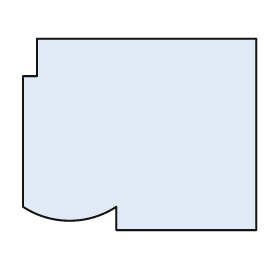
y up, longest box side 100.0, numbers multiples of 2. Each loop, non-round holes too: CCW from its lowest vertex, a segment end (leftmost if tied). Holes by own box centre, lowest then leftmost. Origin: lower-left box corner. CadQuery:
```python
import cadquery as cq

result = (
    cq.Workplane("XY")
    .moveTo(40.0, 0.0)
    .lineTo(100.0, 0.0)
    .lineTo(100.0, 82.0)
    .lineTo(6.0, 82.0)
    .lineTo(6.0, 66.0)
    .lineTo(0.0, 66.0)
    .lineTo(0.0, 10.0)
    .threePointArc((20.0, 4.0), (40.0, 10.0))
    .close()
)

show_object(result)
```